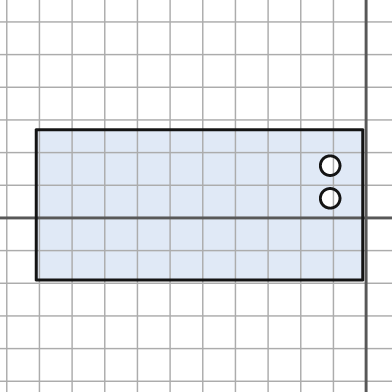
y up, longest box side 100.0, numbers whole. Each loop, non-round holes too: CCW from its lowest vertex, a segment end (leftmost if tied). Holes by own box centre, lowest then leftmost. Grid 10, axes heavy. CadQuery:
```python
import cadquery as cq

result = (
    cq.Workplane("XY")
    .moveTo(-101.0, -19.0)
    .lineTo(-1.0, -19.0)
    .lineTo(-1.0, 27.0)
    .lineTo(-101.0, 27.0)
    .close()
    .moveTo(-11.0, 6.0)
    .circle(3.0)
    .moveTo(-11.0, 16.0)
    .circle(3.0)
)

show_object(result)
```